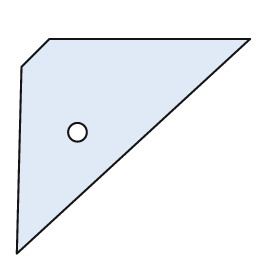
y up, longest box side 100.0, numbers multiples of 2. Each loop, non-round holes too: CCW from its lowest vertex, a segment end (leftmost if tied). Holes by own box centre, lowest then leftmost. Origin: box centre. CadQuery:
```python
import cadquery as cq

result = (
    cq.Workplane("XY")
    .moveTo(-50.0, -46.0)
    .lineTo(50.0, 46.0)
    .lineTo(-36.0, 46.0)
    .lineTo(-48.0, 34.0)
    .close()
    .moveTo(-24.0, 6.0)
    .circle(4.0)
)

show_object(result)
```